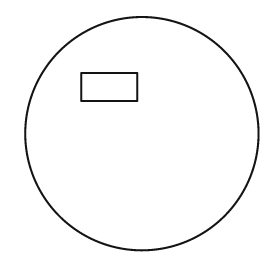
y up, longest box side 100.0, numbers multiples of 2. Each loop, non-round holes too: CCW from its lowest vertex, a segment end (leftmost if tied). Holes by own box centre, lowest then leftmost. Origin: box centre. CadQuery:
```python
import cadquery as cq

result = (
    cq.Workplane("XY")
    .moveTo(0.0, 0.0)
    .circle(50.0)
    .moveTo(-26.0, 14.0)
    .lineTo(-2.0, 14.0)
    .lineTo(-2.0, 26.0)
    .lineTo(-26.0, 26.0)
    .close()
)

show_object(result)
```